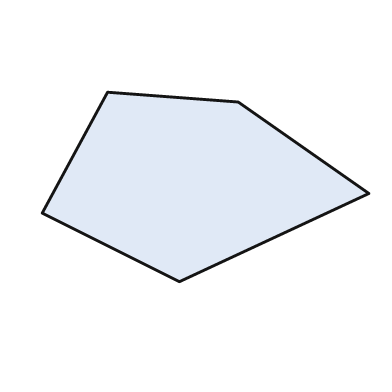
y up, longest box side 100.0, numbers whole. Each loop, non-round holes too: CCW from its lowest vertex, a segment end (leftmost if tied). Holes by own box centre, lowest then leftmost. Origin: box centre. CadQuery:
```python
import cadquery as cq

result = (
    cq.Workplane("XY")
    .moveTo(-8.0, -29.0)
    .lineTo(50.0, -2.0)
    .lineTo(10.0, 26.0)
    .lineTo(-30.0, 29.0)
    .lineTo(-50.0, -8.0)
    .close()
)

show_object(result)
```